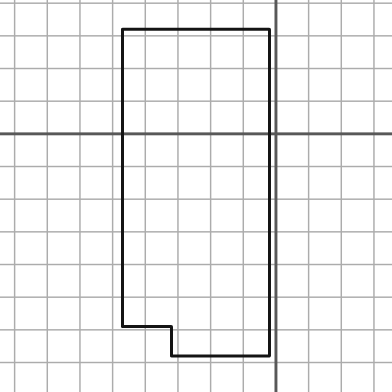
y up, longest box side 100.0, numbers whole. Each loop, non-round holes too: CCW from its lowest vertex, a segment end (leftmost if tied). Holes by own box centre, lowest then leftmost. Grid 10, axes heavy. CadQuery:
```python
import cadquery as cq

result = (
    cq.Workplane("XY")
    .moveTo(-32.0, -68.0)
    .lineTo(-2.0, -68.0)
    .lineTo(-2.0, 32.0)
    .lineTo(-47.0, 32.0)
    .lineTo(-47.0, -59.0)
    .lineTo(-32.0, -59.0)
    .close()
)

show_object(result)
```